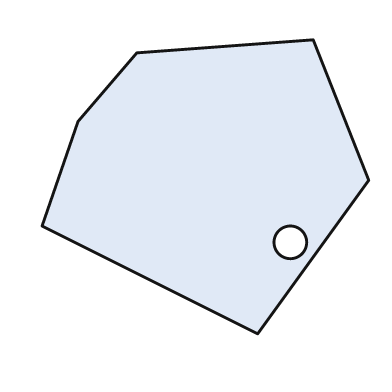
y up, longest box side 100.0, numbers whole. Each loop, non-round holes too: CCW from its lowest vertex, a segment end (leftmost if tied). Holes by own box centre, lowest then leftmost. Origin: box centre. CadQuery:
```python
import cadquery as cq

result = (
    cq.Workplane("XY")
    .moveTo(16.0, -45.0)
    .lineTo(50.0, 2.0)
    .lineTo(33.0, 45.0)
    .lineTo(-21.0, 41.0)
    .lineTo(-39.0, 20.0)
    .lineTo(-50.0, -12.0)
    .close()
    .moveTo(26.0, -17.0)
    .circle(5.0)
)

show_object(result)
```